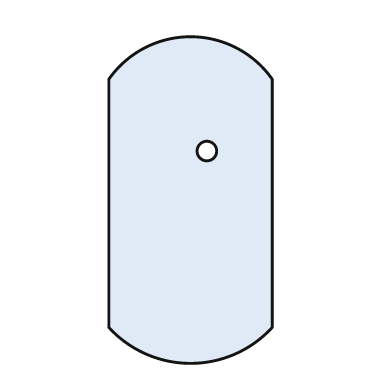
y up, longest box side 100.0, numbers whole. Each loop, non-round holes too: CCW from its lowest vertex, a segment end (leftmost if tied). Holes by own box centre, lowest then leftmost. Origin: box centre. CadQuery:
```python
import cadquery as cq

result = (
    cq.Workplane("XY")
    .moveTo(-25.0, -39.0)
    .threePointArc((0.0, -50.0), (25.0, -39.0))
    .lineTo(25.0, 37.0)
    .threePointArc((0.0, 50.0), (-25.0, 37.0))
    .close()
    .moveTo(5.0, 15.0)
    .circle(3.0)
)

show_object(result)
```